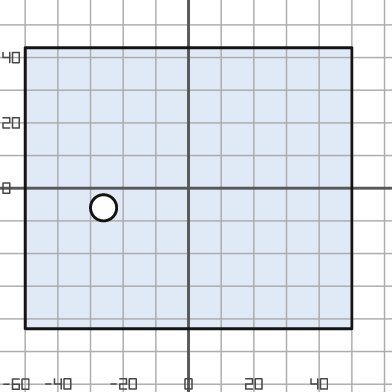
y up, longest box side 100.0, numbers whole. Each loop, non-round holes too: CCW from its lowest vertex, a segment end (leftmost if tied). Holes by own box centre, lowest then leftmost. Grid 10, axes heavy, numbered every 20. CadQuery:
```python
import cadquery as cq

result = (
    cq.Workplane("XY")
    .moveTo(-50.0, -43.0)
    .lineTo(50.0, -43.0)
    .lineTo(50.0, 43.0)
    .lineTo(-50.0, 43.0)
    .close()
    .moveTo(-26.0, -6.0)
    .circle(4.0)
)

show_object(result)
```